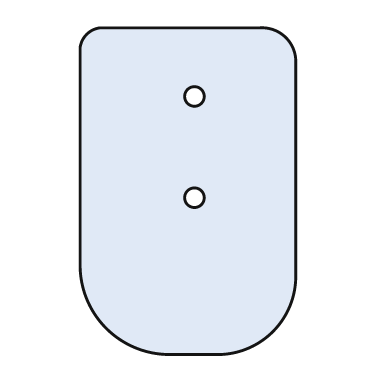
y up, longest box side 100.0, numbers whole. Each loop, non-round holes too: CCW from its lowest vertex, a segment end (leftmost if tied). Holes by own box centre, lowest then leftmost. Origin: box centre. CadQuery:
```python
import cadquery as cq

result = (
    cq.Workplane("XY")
    .moveTo(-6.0, -50.0)
    .lineTo(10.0, -50.0)
    .threePointArc((26.0, -43.0), (33.0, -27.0))
    .lineTo(33.0, 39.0)
    .threePointArc((30.0, 47.0), (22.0, 50.0))
    .lineTo(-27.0, 50.0)
    .threePointArc((-31.0, 48.0), (-33.0, 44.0))
    .lineTo(-33.0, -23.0)
    .threePointArc((-25.0, -42.0), (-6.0, -50.0))
    .close()
    .moveTo(2.0, -2.0)
    .circle(3.0)
    .moveTo(2.0, 29.0)
    .circle(3.0)
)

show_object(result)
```